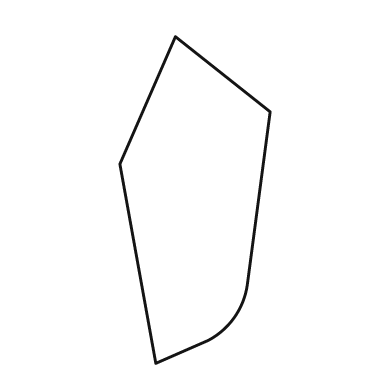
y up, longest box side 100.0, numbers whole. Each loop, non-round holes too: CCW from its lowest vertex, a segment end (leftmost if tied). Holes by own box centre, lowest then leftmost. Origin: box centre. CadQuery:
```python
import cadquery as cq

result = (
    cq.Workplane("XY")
    .moveTo(-12.0, -50.0)
    .lineTo(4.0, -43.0)
    .threePointArc((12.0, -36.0), (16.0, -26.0))
    .lineTo(23.0, 27.0)
    .lineTo(-6.0, 50.0)
    .lineTo(-23.0, 11.0)
    .close()
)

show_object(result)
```